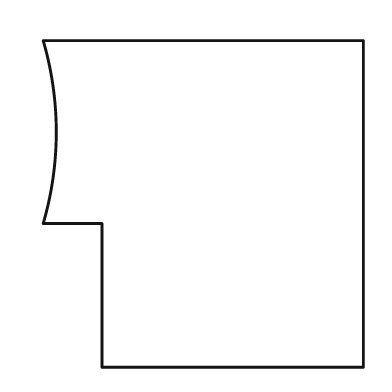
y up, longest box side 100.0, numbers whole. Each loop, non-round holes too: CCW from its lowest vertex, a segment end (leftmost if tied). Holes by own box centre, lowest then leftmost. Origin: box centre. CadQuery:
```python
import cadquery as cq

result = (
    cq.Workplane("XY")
    .moveTo(-31.0, -50.0)
    .lineTo(49.0, -50.0)
    .lineTo(49.0, 50.0)
    .lineTo(-49.0, 50.0)
    .threePointArc((-45.0, 22.0), (-49.0, -6.0))
    .lineTo(-31.0, -6.0)
    .close()
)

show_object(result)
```